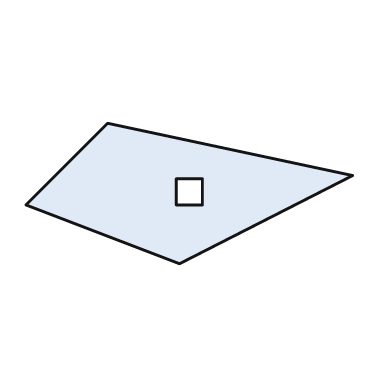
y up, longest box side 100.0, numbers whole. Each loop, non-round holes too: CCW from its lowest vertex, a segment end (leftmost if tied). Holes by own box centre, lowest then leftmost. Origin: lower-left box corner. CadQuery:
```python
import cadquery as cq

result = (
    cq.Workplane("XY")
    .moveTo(47.0, 0.0)
    .lineTo(100.0, 27.0)
    .lineTo(25.0, 43.0)
    .lineTo(0.0, 18.0)
    .close()
    .moveTo(46.0, 18.0)
    .lineTo(54.0, 18.0)
    .lineTo(54.0, 26.0)
    .lineTo(46.0, 26.0)
    .close()
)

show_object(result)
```